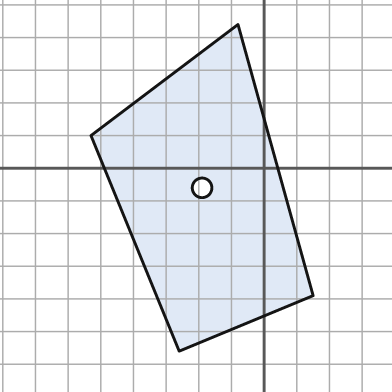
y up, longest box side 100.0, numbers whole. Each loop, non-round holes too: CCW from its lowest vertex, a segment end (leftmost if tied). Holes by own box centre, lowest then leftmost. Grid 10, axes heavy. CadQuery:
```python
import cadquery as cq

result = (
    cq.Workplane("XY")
    .moveTo(-26.0, -56.0)
    .lineTo(15.0, -39.0)
    .lineTo(-8.0, 44.0)
    .lineTo(-53.0, 10.0)
    .close()
    .moveTo(-19.0, -6.0)
    .circle(3.0)
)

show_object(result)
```